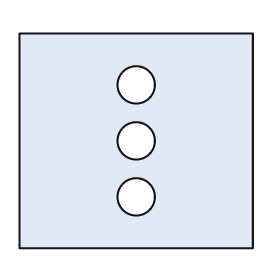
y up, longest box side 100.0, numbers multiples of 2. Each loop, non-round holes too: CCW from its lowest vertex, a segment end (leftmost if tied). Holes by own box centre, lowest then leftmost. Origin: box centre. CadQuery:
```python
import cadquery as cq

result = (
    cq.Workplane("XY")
    .moveTo(-50.0, -46.0)
    .lineTo(50.0, -46.0)
    .lineTo(50.0, 46.0)
    .lineTo(-50.0, 46.0)
    .close()
    .moveTo(0.0, -24.0)
    .circle(8.0)
    .moveTo(0.0, 0.0)
    .circle(8.0)
    .moveTo(0.0, 24.0)
    .circle(8.0)
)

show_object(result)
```